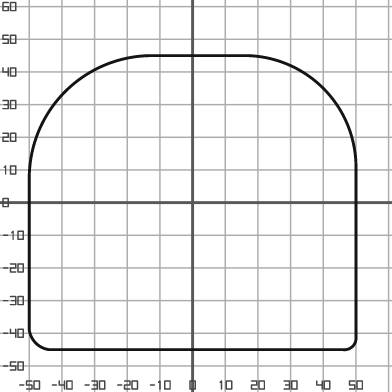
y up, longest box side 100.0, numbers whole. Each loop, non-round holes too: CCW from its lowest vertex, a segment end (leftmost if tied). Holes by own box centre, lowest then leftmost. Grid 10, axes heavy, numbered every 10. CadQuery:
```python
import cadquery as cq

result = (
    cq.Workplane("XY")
    .moveTo(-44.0, -45.0)
    .lineTo(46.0, -45.0)
    .threePointArc((49.0, -44.0), (50.0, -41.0))
    .lineTo(50.0, 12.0)
    .threePointArc((40.0, 35.0), (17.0, 45.0))
    .lineTo(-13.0, 45.0)
    .threePointArc((-39.0, 34.0), (-50.0, 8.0))
    .lineTo(-50.0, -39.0)
    .threePointArc((-48.0, -43.0), (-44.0, -45.0))
    .close()
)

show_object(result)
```